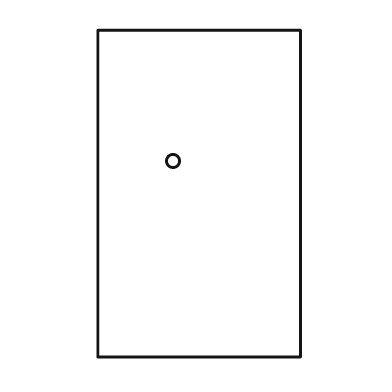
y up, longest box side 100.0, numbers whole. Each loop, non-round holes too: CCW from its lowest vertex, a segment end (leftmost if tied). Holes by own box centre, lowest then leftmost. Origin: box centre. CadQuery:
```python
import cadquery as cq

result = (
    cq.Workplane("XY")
    .moveTo(-31.0, -50.0)
    .lineTo(31.0, -50.0)
    .lineTo(31.0, 50.0)
    .lineTo(-31.0, 50.0)
    .close()
    .moveTo(-8.0, 10.0)
    .circle(2.0)
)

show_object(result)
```